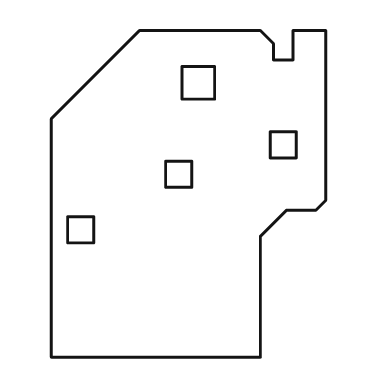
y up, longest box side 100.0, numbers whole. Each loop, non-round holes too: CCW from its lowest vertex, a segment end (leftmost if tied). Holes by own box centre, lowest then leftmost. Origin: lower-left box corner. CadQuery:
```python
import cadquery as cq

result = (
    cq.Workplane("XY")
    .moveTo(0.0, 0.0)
    .lineTo(64.0, 0.0)
    .lineTo(64.0, 37.0)
    .lineTo(72.0, 45.0)
    .lineTo(81.0, 45.0)
    .lineTo(84.0, 48.0)
    .lineTo(84.0, 100.0)
    .lineTo(74.0, 100.0)
    .lineTo(74.0, 91.0)
    .lineTo(68.0, 91.0)
    .lineTo(68.0, 96.0)
    .lineTo(64.0, 100.0)
    .lineTo(27.0, 100.0)
    .lineTo(0.0, 73.0)
    .close()
    .moveTo(5.0, 35.0)
    .lineTo(13.0, 35.0)
    .lineTo(13.0, 43.0)
    .lineTo(5.0, 43.0)
    .close()
    .moveTo(35.0, 52.0)
    .lineTo(43.0, 52.0)
    .lineTo(43.0, 60.0)
    .lineTo(35.0, 60.0)
    .close()
    .moveTo(67.0, 61.0)
    .lineTo(75.0, 61.0)
    .lineTo(75.0, 69.0)
    .lineTo(67.0, 69.0)
    .close()
    .moveTo(40.0, 79.0)
    .lineTo(50.0, 79.0)
    .lineTo(50.0, 89.0)
    .lineTo(40.0, 89.0)
    .close()
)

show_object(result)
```